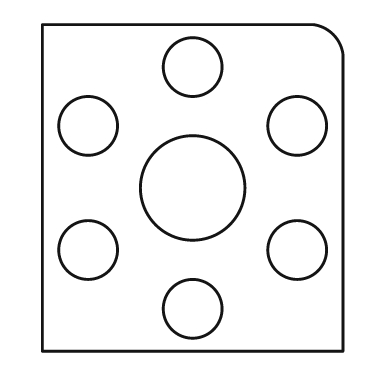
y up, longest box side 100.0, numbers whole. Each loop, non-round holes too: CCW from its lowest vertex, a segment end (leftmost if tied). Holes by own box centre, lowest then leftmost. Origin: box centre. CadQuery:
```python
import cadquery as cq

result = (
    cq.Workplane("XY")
    .moveTo(-46.0, -50.0)
    .lineTo(46.0, -50.0)
    .lineTo(46.0, 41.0)
    .threePointArc((43.0, 47.0), (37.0, 50.0))
    .lineTo(-46.0, 50.0)
    .close()
    .moveTo(0.0, -37.0)
    .circle(9.0)
    .moveTo(-32.0, -19.0)
    .circle(9.0)
    .moveTo(32.0, -19.0)
    .circle(9.0)
    .moveTo(0.0, 0.0)
    .circle(16.0)
    .moveTo(-32.0, 19.0)
    .circle(9.0)
    .moveTo(32.0, 19.0)
    .circle(9.0)
    .moveTo(0.0, 37.0)
    .circle(9.0)
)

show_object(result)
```